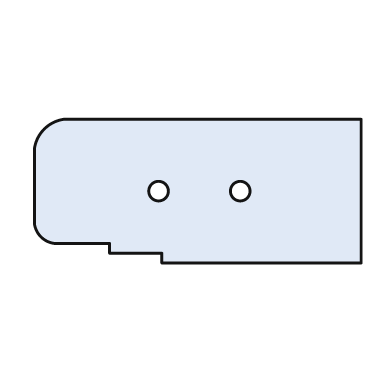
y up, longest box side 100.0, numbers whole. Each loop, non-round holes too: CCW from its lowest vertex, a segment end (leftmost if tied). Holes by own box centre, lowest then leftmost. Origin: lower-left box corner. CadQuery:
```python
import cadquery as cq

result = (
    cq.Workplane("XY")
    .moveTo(39.0, 0.0)
    .lineTo(100.0, 0.0)
    .lineTo(100.0, 44.0)
    .lineTo(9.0, 44.0)
    .threePointArc((3.0, 41.0), (0.0, 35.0))
    .lineTo(0.0, 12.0)
    .threePointArc((2.0, 8.0), (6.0, 6.0))
    .lineTo(23.0, 6.0)
    .lineTo(23.0, 3.0)
    .lineTo(39.0, 3.0)
    .close()
    .moveTo(38.0, 22.0)
    .circle(3.0)
    .moveTo(63.0, 22.0)
    .circle(3.0)
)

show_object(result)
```